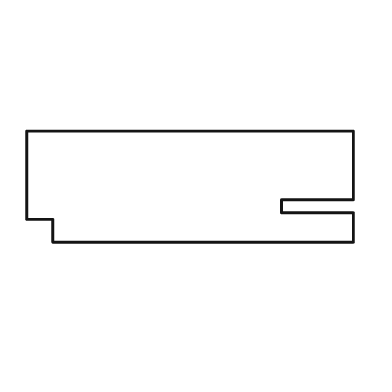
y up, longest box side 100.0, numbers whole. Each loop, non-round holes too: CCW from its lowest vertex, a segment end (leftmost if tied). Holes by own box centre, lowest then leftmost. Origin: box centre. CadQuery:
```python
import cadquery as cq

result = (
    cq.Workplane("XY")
    .moveTo(-42.0, -17.0)
    .lineTo(50.0, -17.0)
    .lineTo(50.0, -8.0)
    .lineTo(28.0, -8.0)
    .lineTo(28.0, -4.0)
    .lineTo(50.0, -4.0)
    .lineTo(50.0, 17.0)
    .lineTo(-50.0, 17.0)
    .lineTo(-50.0, -10.0)
    .lineTo(-42.0, -10.0)
    .close()
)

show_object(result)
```